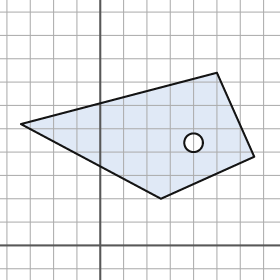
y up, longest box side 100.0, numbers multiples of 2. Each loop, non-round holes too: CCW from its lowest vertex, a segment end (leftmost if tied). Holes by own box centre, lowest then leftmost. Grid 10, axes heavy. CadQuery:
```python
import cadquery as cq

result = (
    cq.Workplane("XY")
    .moveTo(26.0, 20.0)
    .lineTo(66.0, 38.0)
    .lineTo(50.0, 74.0)
    .lineTo(-34.0, 52.0)
    .close()
    .moveTo(40.0, 44.0)
    .circle(4.0)
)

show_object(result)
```